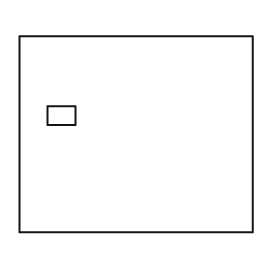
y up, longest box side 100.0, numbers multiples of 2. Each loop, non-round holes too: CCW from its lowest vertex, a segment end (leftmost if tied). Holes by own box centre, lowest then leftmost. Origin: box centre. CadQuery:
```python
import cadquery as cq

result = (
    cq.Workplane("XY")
    .moveTo(-50.0, -42.0)
    .lineTo(50.0, -42.0)
    .lineTo(50.0, 42.0)
    .lineTo(-50.0, 42.0)
    .close()
    .moveTo(-38.0, 4.0)
    .lineTo(-26.0, 4.0)
    .lineTo(-26.0, 12.0)
    .lineTo(-38.0, 12.0)
    .close()
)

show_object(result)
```